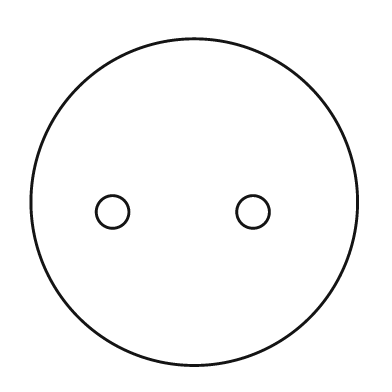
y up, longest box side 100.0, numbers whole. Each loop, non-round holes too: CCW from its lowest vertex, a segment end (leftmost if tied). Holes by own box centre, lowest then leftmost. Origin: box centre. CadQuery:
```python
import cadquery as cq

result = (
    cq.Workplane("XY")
    .moveTo(0.0, 0.0)
    .circle(50.0)
    .moveTo(-25.0, -3.0)
    .circle(5.0)
    .moveTo(18.0, -3.0)
    .circle(5.0)
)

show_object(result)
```